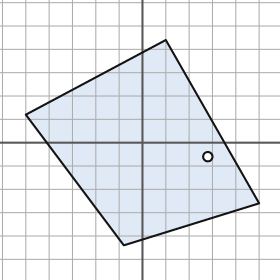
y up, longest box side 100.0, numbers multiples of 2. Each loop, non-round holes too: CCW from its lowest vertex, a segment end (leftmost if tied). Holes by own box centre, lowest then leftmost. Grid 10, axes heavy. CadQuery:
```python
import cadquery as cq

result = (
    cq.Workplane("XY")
    .moveTo(-8.0, -44.0)
    .lineTo(50.0, -26.0)
    .lineTo(10.0, 44.0)
    .lineTo(-50.0, 12.0)
    .close()
    .moveTo(28.0, -6.0)
    .circle(2.0)
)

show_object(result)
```